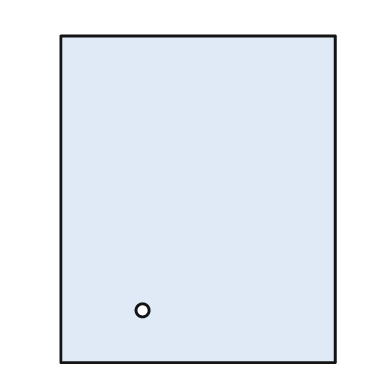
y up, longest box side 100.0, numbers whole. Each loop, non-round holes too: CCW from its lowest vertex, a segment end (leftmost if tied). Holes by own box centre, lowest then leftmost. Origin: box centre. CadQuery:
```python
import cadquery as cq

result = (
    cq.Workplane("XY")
    .moveTo(-42.0, -50.0)
    .lineTo(42.0, -50.0)
    .lineTo(42.0, 50.0)
    .lineTo(-42.0, 50.0)
    .close()
    .moveTo(-17.0, -34.0)
    .circle(2.0)
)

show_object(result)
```